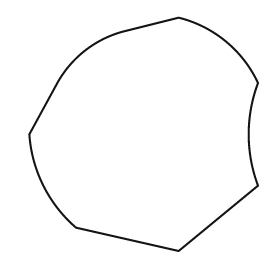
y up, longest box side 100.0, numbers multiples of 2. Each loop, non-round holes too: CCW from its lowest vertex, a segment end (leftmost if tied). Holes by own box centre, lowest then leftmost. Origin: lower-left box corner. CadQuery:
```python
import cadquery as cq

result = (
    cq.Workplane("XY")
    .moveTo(64.0, 0.0)
    .lineTo(98.0, 28.0)
    .threePointArc((94.0, 50.0), (98.0, 72.0))
    .threePointArc((84.0, 90.0), (64.0, 100.0))
    .lineTo(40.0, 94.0)
    .threePointArc((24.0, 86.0), (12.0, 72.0))
    .lineTo(0.0, 50.0)
    .threePointArc((6.0, 28.0), (20.0, 10.0))
    .close()
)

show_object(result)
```